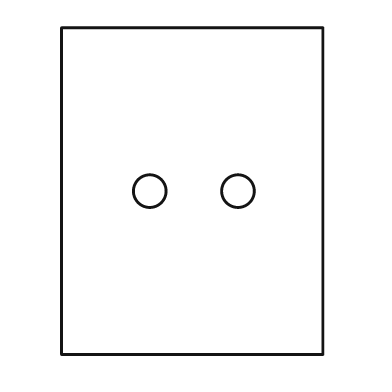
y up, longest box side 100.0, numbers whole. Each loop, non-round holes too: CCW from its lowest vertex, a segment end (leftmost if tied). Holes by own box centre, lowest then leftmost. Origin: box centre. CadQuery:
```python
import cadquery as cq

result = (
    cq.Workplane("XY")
    .moveTo(-40.0, -50.0)
    .lineTo(40.0, -50.0)
    .lineTo(40.0, 50.0)
    .lineTo(-40.0, 50.0)
    .close()
    .moveTo(-13.0, 0.0)
    .circle(5.0)
    .moveTo(14.0, 0.0)
    .circle(5.0)
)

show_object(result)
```